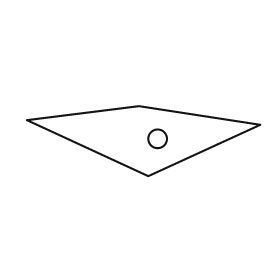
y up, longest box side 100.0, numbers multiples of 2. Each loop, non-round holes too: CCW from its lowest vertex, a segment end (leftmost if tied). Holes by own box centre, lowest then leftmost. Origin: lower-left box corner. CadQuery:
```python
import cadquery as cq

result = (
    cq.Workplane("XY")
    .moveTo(52.0, 0.0)
    .lineTo(100.0, 22.0)
    .lineTo(48.0, 30.0)
    .lineTo(0.0, 24.0)
    .close()
    .moveTo(56.0, 16.0)
    .circle(4.0)
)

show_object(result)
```